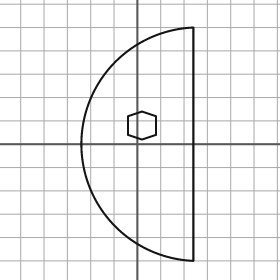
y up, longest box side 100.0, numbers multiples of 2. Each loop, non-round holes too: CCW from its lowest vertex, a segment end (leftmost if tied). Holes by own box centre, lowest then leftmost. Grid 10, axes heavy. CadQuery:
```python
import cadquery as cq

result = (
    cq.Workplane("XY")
    .moveTo(24.0, -50.0)
    .lineTo(24.0, 50.0)
    .threePointArc((-24.0, 0.0), (24.0, -50.0))
    .close()
    .moveTo(2.0, 2.0)
    .lineTo(8.0, 4.0)
    .lineTo(8.0, 12.0)
    .lineTo(2.0, 14.0)
    .lineTo(-4.0, 12.0)
    .lineTo(-4.0, 4.0)
    .close()
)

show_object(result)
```